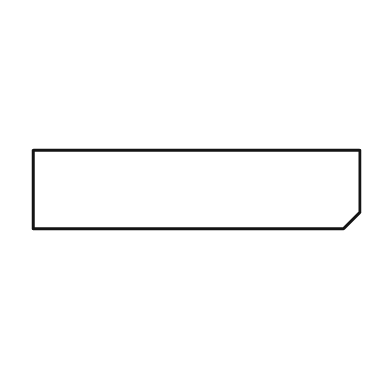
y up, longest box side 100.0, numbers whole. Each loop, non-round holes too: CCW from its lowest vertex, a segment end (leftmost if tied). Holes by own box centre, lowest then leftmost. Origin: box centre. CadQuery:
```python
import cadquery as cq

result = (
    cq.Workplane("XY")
    .moveTo(-50.0, -12.0)
    .lineTo(45.0, -12.0)
    .lineTo(50.0, -7.0)
    .lineTo(50.0, 12.0)
    .lineTo(-50.0, 12.0)
    .close()
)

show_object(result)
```